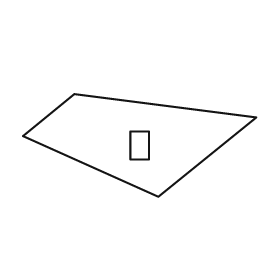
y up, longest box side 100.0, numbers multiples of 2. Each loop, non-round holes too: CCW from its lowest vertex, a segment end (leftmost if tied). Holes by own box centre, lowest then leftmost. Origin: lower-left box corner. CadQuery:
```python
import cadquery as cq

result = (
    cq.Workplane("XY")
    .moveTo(58.0, 0.0)
    .lineTo(100.0, 34.0)
    .lineTo(22.0, 44.0)
    .lineTo(0.0, 26.0)
    .close()
    .moveTo(46.0, 16.0)
    .lineTo(54.0, 16.0)
    .lineTo(54.0, 28.0)
    .lineTo(46.0, 28.0)
    .close()
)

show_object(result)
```